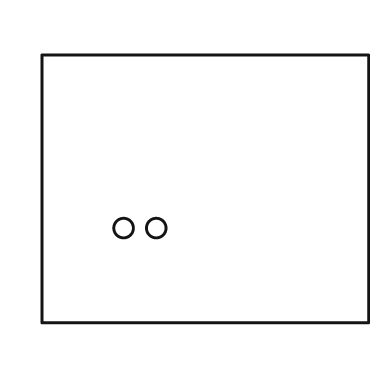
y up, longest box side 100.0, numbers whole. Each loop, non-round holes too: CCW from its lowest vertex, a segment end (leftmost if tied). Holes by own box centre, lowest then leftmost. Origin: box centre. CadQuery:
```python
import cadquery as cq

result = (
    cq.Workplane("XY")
    .moveTo(-50.0, -41.0)
    .lineTo(50.0, -41.0)
    .lineTo(50.0, 41.0)
    .lineTo(-50.0, 41.0)
    .close()
    .moveTo(-25.0, -12.0)
    .circle(3.0)
    .moveTo(-15.0, -12.0)
    .circle(3.0)
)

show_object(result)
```